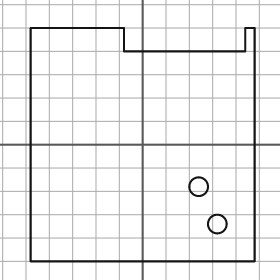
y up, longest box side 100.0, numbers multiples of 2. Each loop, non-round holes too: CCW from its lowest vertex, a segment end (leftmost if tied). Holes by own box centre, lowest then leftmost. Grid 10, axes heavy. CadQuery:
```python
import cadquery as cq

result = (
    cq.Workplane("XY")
    .moveTo(-48.0, -50.0)
    .lineTo(48.0, -50.0)
    .lineTo(48.0, 50.0)
    .lineTo(44.0, 50.0)
    .lineTo(44.0, 40.0)
    .lineTo(-8.0, 40.0)
    .lineTo(-8.0, 50.0)
    .lineTo(-48.0, 50.0)
    .close()
    .moveTo(32.0, -34.0)
    .circle(4.0)
    .moveTo(24.0, -18.0)
    .circle(4.0)
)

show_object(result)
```